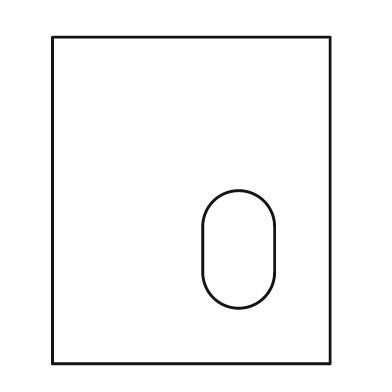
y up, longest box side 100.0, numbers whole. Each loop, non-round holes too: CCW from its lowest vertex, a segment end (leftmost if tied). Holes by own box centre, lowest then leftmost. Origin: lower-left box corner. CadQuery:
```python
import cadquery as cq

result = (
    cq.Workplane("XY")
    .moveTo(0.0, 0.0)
    .lineTo(85.0, 0.0)
    .lineTo(85.0, 100.0)
    .lineTo(0.0, 100.0)
    .close()
    .moveTo(46.0, 28.0)
    .threePointArc((57.0, 17.0), (68.0, 28.0))
    .lineTo(68.0, 42.0)
    .threePointArc((57.0, 53.0), (46.0, 42.0))
    .close()
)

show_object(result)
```